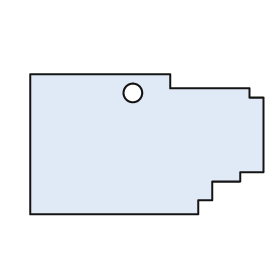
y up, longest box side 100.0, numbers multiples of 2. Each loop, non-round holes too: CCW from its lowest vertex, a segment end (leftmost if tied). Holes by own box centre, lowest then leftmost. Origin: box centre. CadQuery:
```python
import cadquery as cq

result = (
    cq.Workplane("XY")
    .moveTo(-50.0, -30.0)
    .lineTo(22.0, -30.0)
    .lineTo(22.0, -24.0)
    .lineTo(28.0, -24.0)
    .lineTo(28.0, -16.0)
    .lineTo(40.0, -16.0)
    .lineTo(40.0, -12.0)
    .lineTo(50.0, -12.0)
    .lineTo(50.0, 20.0)
    .lineTo(44.0, 20.0)
    .lineTo(44.0, 24.0)
    .lineTo(10.0, 24.0)
    .lineTo(10.0, 30.0)
    .lineTo(-50.0, 30.0)
    .close()
    .moveTo(-6.0, 22.0)
    .circle(4.0)
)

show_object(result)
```